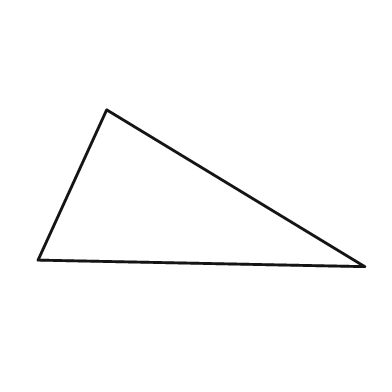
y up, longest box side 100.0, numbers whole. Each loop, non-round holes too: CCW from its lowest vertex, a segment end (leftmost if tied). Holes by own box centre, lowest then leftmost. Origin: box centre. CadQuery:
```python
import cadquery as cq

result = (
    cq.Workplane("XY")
    .moveTo(50.0, -24.0)
    .lineTo(-29.0, 24.0)
    .lineTo(-50.0, -22.0)
    .close()
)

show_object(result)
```